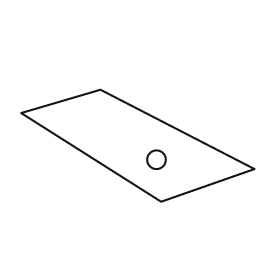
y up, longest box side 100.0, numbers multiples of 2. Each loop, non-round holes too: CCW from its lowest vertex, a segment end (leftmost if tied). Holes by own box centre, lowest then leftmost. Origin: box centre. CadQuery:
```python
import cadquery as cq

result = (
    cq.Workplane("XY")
    .moveTo(10.0, -24.0)
    .lineTo(50.0, -10.0)
    .lineTo(-16.0, 24.0)
    .lineTo(-50.0, 14.0)
    .close()
    .moveTo(8.0, -6.0)
    .circle(4.0)
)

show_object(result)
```